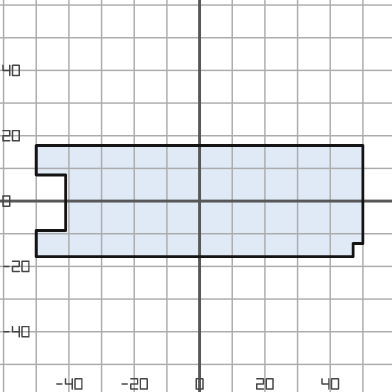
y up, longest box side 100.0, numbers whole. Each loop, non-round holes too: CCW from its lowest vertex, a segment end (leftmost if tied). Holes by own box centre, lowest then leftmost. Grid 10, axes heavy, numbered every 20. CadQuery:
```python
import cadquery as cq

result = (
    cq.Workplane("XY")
    .moveTo(-50.0, -17.0)
    .lineTo(47.0, -17.0)
    .lineTo(47.0, -13.0)
    .lineTo(50.0, -13.0)
    .lineTo(50.0, 17.0)
    .lineTo(-50.0, 17.0)
    .lineTo(-50.0, 8.0)
    .lineTo(-41.0, 8.0)
    .lineTo(-41.0, -9.0)
    .lineTo(-50.0, -9.0)
    .close()
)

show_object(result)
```